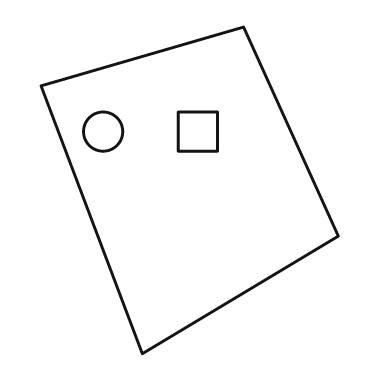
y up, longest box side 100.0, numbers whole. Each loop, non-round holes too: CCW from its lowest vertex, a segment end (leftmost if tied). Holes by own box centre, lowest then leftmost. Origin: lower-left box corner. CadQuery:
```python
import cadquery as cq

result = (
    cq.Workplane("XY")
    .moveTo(31.0, 0.0)
    .lineTo(91.0, 36.0)
    .lineTo(62.0, 100.0)
    .lineTo(0.0, 82.0)
    .close()
    .moveTo(19.0, 68.0)
    .circle(6.0)
    .moveTo(42.0, 62.0)
    .lineTo(54.0, 62.0)
    .lineTo(54.0, 74.0)
    .lineTo(42.0, 74.0)
    .close()
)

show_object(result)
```